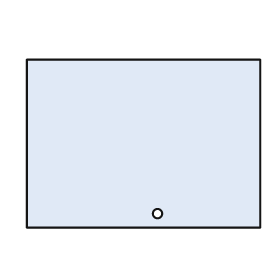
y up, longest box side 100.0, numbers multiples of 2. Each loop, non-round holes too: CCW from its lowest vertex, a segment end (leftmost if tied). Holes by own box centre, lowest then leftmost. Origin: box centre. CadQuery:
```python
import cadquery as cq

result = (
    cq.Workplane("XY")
    .moveTo(-50.0, -36.0)
    .lineTo(50.0, -36.0)
    .lineTo(50.0, 36.0)
    .lineTo(-50.0, 36.0)
    .close()
    .moveTo(6.0, -30.0)
    .circle(2.0)
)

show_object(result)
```